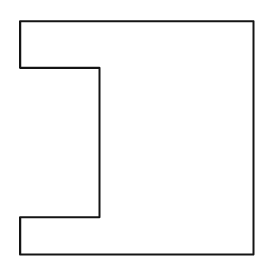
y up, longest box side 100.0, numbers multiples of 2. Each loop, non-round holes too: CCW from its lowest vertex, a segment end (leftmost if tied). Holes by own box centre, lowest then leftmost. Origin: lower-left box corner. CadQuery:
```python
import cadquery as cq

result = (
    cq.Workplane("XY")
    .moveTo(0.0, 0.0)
    .lineTo(100.0, 0.0)
    .lineTo(100.0, 100.0)
    .lineTo(0.0, 100.0)
    .lineTo(0.0, 80.0)
    .lineTo(34.0, 80.0)
    .lineTo(34.0, 16.0)
    .lineTo(0.0, 16.0)
    .close()
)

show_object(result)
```